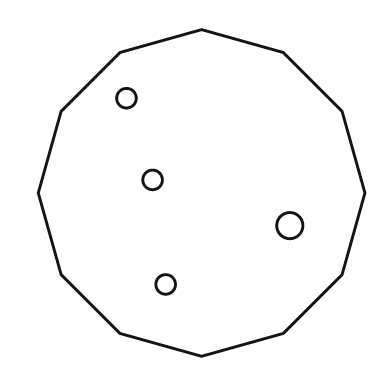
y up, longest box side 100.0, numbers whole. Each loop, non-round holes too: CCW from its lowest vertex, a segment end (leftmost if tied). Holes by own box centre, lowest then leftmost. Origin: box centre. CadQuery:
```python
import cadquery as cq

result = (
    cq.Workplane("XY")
    .moveTo(0.0, -50.0)
    .lineTo(25.0, -43.0)
    .lineTo(43.0, -25.0)
    .lineTo(50.0, 0.0)
    .lineTo(43.0, 25.0)
    .lineTo(25.0, 43.0)
    .lineTo(0.0, 50.0)
    .lineTo(-25.0, 43.0)
    .lineTo(-43.0, 25.0)
    .lineTo(-50.0, 0.0)
    .lineTo(-43.0, -25.0)
    .lineTo(-25.0, -43.0)
    .close()
    .moveTo(-11.0, -28.0)
    .circle(3.0)
    .moveTo(27.0, -10.0)
    .circle(4.0)
    .moveTo(-15.0, 4.0)
    .circle(3.0)
    .moveTo(-23.0, 29.0)
    .circle(3.0)
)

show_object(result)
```